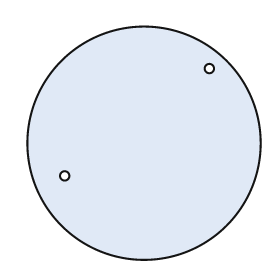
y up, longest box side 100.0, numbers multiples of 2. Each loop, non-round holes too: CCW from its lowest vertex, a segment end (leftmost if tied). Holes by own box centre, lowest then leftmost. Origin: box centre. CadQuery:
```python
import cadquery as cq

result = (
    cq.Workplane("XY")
    .moveTo(0.0, 0.0)
    .circle(50.0)
    .moveTo(-34.0, -14.0)
    .circle(2.0)
    .moveTo(28.0, 32.0)
    .circle(2.0)
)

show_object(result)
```